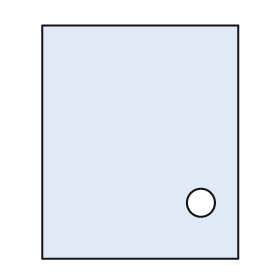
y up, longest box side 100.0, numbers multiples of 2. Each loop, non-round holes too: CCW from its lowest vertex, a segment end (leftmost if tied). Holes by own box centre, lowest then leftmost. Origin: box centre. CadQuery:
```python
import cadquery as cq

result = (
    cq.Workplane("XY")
    .moveTo(-42.0, -50.0)
    .lineTo(42.0, -50.0)
    .lineTo(42.0, 50.0)
    .lineTo(-42.0, 50.0)
    .close()
    .moveTo(26.0, -26.0)
    .circle(6.0)
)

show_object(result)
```